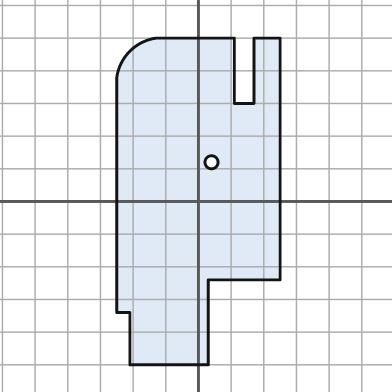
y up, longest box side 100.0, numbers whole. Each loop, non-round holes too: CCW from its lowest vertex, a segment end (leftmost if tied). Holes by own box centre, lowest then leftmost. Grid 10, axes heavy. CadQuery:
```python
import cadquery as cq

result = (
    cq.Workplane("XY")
    .moveTo(-21.0, -50.0)
    .lineTo(3.0, -50.0)
    .lineTo(3.0, -24.0)
    .lineTo(25.0, -24.0)
    .lineTo(25.0, 50.0)
    .lineTo(17.0, 50.0)
    .lineTo(17.0, 30.0)
    .lineTo(11.0, 30.0)
    .lineTo(11.0, 50.0)
    .lineTo(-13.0, 50.0)
    .threePointArc((-21.0, 46.0), (-25.0, 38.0))
    .lineTo(-25.0, -34.0)
    .lineTo(-21.0, -34.0)
    .close()
    .moveTo(4.0, 12.0)
    .circle(2.0)
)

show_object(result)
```